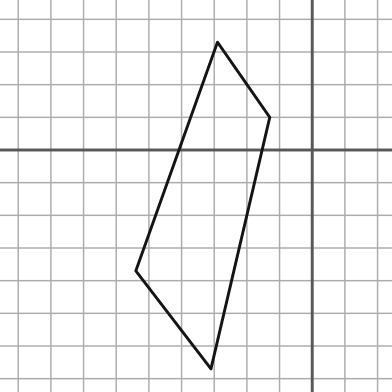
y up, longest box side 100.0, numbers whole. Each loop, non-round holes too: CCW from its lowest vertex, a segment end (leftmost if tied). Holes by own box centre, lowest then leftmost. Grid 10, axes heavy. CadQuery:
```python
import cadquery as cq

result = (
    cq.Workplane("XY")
    .moveTo(-31.0, -67.0)
    .lineTo(-13.0, 10.0)
    .lineTo(-29.0, 33.0)
    .lineTo(-54.0, -37.0)
    .close()
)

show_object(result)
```